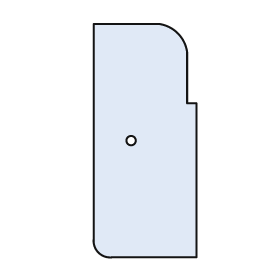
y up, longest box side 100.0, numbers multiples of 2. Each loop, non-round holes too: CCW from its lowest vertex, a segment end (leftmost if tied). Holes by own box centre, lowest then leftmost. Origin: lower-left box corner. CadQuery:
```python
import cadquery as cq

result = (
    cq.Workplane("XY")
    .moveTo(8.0, 0.0)
    .lineTo(44.0, 0.0)
    .lineTo(44.0, 66.0)
    .lineTo(40.0, 66.0)
    .lineTo(40.0, 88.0)
    .threePointArc((36.0, 96.0), (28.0, 100.0))
    .lineTo(0.0, 100.0)
    .lineTo(0.0, 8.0)
    .threePointArc((2.0, 2.0), (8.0, 0.0))
    .close()
    .moveTo(16.0, 50.0)
    .circle(2.0)
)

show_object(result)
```